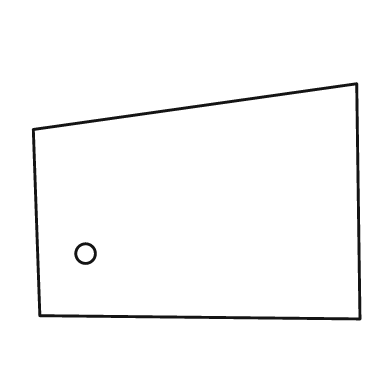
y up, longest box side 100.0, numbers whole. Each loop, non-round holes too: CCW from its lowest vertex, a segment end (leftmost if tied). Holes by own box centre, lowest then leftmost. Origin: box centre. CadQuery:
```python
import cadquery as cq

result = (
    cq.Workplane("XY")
    .moveTo(50.0, -36.0)
    .lineTo(49.0, 36.0)
    .lineTo(-50.0, 22.0)
    .lineTo(-48.0, -35.0)
    .close()
    .moveTo(-34.0, -16.0)
    .circle(3.0)
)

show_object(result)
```